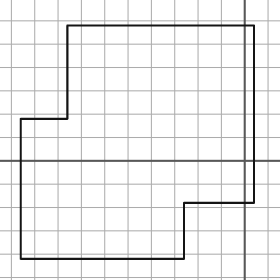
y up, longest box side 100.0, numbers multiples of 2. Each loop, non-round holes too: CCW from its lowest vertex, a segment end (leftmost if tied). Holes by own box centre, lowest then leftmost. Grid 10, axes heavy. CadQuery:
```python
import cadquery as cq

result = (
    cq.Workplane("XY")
    .moveTo(-96.0, -42.0)
    .lineTo(-26.0, -42.0)
    .lineTo(-26.0, -18.0)
    .lineTo(4.0, -18.0)
    .lineTo(4.0, 58.0)
    .lineTo(-76.0, 58.0)
    .lineTo(-76.0, 18.0)
    .lineTo(-96.0, 18.0)
    .close()
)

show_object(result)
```